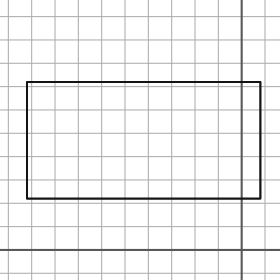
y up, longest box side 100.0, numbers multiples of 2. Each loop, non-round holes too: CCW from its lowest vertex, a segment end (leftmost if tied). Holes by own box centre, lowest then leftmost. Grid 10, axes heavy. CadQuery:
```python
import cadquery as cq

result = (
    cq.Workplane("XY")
    .moveTo(-92.0, 22.0)
    .lineTo(8.0, 22.0)
    .lineTo(8.0, 72.0)
    .lineTo(-92.0, 72.0)
    .close()
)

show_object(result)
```